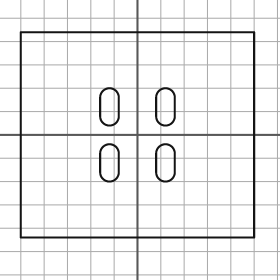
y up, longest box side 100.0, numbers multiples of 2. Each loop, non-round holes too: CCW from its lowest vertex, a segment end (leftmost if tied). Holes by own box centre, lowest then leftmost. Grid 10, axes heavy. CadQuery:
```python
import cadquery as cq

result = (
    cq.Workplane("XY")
    .moveTo(-50.0, -44.0)
    .lineTo(50.0, -44.0)
    .lineTo(50.0, 44.0)
    .lineTo(-50.0, 44.0)
    .close()
    .moveTo(-16.0, -16.0)
    .threePointArc((-12.0, -20.0), (-8.0, -16.0))
    .lineTo(-8.0, -8.0)
    .threePointArc((-12.0, -4.0), (-16.0, -8.0))
    .close()
    .moveTo(8.0, -16.0)
    .threePointArc((12.0, -20.0), (16.0, -16.0))
    .lineTo(16.0, -8.0)
    .threePointArc((12.0, -4.0), (8.0, -8.0))
    .close()
    .moveTo(-16.0, 8.0)
    .threePointArc((-12.0, 4.0), (-8.0, 8.0))
    .lineTo(-8.0, 16.0)
    .threePointArc((-12.0, 20.0), (-16.0, 16.0))
    .close()
    .moveTo(8.0, 8.0)
    .threePointArc((12.0, 4.0), (16.0, 8.0))
    .lineTo(16.0, 16.0)
    .threePointArc((12.0, 20.0), (8.0, 16.0))
    .close()
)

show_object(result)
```